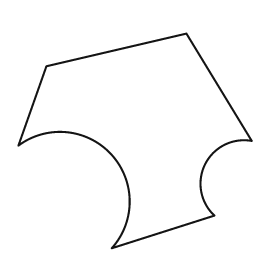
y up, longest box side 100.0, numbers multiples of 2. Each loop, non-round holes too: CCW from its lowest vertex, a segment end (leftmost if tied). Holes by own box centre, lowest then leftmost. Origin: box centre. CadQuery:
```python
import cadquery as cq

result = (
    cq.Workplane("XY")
    .moveTo(-10.0, -46.0)
    .lineTo(34.0, -32.0)
    .threePointArc((30.0, -10.0), (50.0, 0.0))
    .lineTo(22.0, 46.0)
    .lineTo(-38.0, 32.0)
    .lineTo(-50.0, -2.0)
    .threePointArc((-10.0, -6.0), (-10.0, -46.0))
    .close()
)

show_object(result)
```